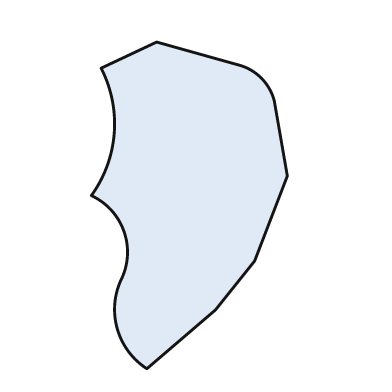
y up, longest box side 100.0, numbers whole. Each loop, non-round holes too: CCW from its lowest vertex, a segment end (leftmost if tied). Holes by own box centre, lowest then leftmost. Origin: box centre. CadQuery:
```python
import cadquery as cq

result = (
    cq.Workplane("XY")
    .moveTo(-13.0, -50.0)
    .lineTo(8.0, -32.0)
    .lineTo(20.0, -17.0)
    .lineTo(30.0, 9.0)
    .lineTo(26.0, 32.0)
    .threePointArc((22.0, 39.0), (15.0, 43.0))
    .lineTo(-10.0, 50.0)
    .lineTo(-27.0, 42.0)
    .threePointArc((-23.0, 22.0), (-30.0, 3.0))
    .threePointArc((-20.0, -8.0), (-21.0, -23.0))
    .threePointArc((-22.0, -38.0), (-13.0, -50.0))
    .close()
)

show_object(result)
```